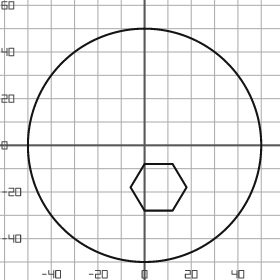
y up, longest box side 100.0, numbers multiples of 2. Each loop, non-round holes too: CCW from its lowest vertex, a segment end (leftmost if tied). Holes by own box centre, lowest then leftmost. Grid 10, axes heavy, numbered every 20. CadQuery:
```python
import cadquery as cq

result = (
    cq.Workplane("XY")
    .moveTo(0.0, 0.0)
    .circle(50.0)
    .moveTo(0.0, -28.0)
    .lineTo(12.0, -28.0)
    .lineTo(18.0, -18.0)
    .lineTo(12.0, -8.0)
    .lineTo(0.0, -8.0)
    .lineTo(-6.0, -18.0)
    .close()
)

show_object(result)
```